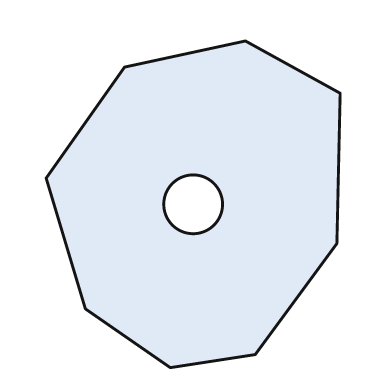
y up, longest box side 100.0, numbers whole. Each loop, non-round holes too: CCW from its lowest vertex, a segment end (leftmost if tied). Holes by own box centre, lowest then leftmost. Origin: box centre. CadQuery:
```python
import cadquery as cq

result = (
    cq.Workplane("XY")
    .moveTo(-7.0, -50.0)
    .lineTo(19.0, -46.0)
    .lineTo(44.0, -12.0)
    .lineTo(45.0, 34.0)
    .lineTo(16.0, 50.0)
    .lineTo(-21.0, 42.0)
    .lineTo(-45.0, 8.0)
    .lineTo(-33.0, -32.0)
    .close()
    .moveTo(0.0, 0.0)
    .circle(9.0)
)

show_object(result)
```